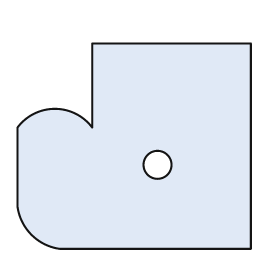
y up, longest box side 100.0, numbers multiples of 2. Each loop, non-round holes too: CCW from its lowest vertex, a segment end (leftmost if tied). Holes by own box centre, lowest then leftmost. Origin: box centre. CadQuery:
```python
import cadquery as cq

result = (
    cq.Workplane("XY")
    .moveTo(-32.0, -44.0)
    .lineTo(50.0, -44.0)
    .lineTo(50.0, 44.0)
    .lineTo(-18.0, 44.0)
    .lineTo(-18.0, 8.0)
    .threePointArc((-34.0, 16.0), (-50.0, 8.0))
    .lineTo(-50.0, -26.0)
    .threePointArc((-44.0, -38.0), (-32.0, -44.0))
    .close()
    .moveTo(10.0, -8.0)
    .circle(6.0)
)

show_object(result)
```